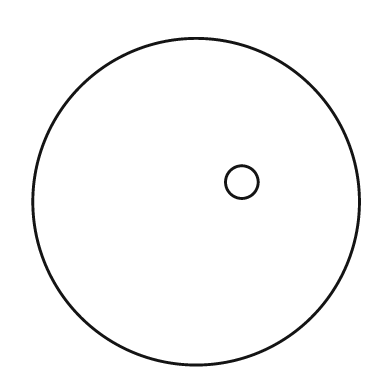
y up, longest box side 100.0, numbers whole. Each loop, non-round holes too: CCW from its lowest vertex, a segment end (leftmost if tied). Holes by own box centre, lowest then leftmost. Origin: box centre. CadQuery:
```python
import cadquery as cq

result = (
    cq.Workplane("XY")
    .moveTo(0.0, 0.0)
    .circle(50.0)
    .moveTo(14.0, 6.0)
    .circle(5.0)
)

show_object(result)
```